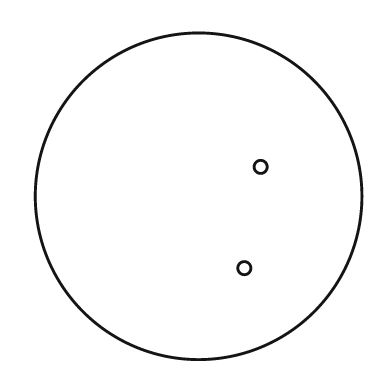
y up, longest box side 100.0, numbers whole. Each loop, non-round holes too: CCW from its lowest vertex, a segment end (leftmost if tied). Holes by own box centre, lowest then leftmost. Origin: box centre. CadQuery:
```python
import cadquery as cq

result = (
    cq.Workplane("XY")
    .moveTo(0.0, 0.0)
    .circle(50.0)
    .moveTo(14.0, -22.0)
    .circle(2.0)
    .moveTo(19.0, 9.0)
    .circle(2.0)
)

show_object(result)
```